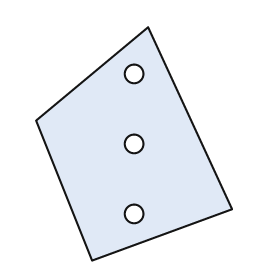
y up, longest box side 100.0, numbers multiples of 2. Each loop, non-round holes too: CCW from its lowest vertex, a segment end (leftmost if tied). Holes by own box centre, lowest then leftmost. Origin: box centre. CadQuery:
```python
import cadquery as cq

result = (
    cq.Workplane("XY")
    .moveTo(-18.0, -50.0)
    .lineTo(42.0, -28.0)
    .lineTo(6.0, 50.0)
    .lineTo(-42.0, 10.0)
    .close()
    .moveTo(0.0, -30.0)
    .circle(4.0)
    .moveTo(0.0, 0.0)
    .circle(4.0)
    .moveTo(0.0, 30.0)
    .circle(4.0)
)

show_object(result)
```